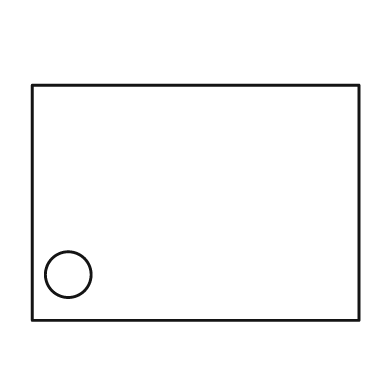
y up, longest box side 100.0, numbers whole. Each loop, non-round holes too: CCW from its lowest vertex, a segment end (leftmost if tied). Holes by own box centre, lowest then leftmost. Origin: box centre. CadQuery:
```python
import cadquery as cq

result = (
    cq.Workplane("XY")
    .moveTo(-50.0, -36.0)
    .lineTo(50.0, -36.0)
    .lineTo(50.0, 36.0)
    .lineTo(-50.0, 36.0)
    .close()
    .moveTo(-39.0, -22.0)
    .circle(7.0)
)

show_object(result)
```